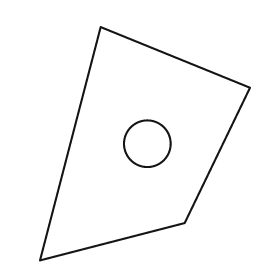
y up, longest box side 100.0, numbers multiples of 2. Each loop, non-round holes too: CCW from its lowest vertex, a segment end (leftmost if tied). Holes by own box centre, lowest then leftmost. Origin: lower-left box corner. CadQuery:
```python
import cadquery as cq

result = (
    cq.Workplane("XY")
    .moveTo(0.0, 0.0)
    .lineTo(62.0, 16.0)
    .lineTo(90.0, 74.0)
    .lineTo(26.0, 100.0)
    .close()
    .moveTo(46.0, 50.0)
    .circle(10.0)
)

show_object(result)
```